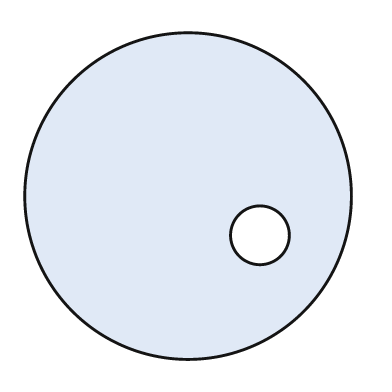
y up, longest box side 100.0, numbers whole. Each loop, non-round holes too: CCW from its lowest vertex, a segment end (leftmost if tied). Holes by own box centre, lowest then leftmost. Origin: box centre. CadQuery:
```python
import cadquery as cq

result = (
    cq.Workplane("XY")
    .moveTo(0.0, 0.0)
    .circle(50.0)
    .moveTo(22.0, -12.0)
    .circle(9.0)
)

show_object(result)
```